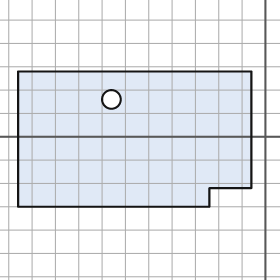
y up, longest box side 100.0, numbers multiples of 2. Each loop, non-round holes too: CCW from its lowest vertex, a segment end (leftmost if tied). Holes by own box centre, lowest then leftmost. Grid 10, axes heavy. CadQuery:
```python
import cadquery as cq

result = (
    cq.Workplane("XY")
    .moveTo(-106.0, -30.0)
    .lineTo(-24.0, -30.0)
    .lineTo(-24.0, -22.0)
    .lineTo(-6.0, -22.0)
    .lineTo(-6.0, 28.0)
    .lineTo(-106.0, 28.0)
    .close()
    .moveTo(-66.0, 16.0)
    .circle(4.0)
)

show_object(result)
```